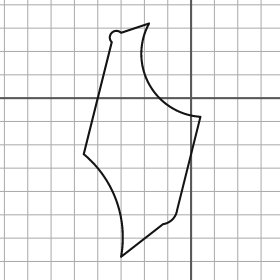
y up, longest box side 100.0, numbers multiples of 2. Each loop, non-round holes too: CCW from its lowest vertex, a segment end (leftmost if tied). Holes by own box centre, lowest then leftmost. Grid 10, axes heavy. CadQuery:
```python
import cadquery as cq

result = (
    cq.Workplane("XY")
    .moveTo(-30.0, -68.0)
    .lineTo(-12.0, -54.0)
    .threePointArc((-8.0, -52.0), (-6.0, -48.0))
    .lineTo(4.0, -8.0)
    .threePointArc((-18.0, 6.0), (-18.0, 32.0))
    .lineTo(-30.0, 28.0)
    .threePointArc((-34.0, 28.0), (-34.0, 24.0))
    .lineTo(-46.0, -24.0)
    .threePointArc((-32.0, -44.0), (-30.0, -68.0))
    .close()
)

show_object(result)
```